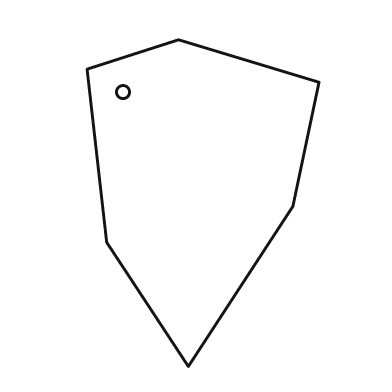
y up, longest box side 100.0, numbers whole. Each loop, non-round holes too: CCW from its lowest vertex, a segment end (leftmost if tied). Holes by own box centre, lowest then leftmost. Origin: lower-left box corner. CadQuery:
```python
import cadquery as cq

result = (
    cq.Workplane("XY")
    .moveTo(31.0, 0.0)
    .lineTo(63.0, 49.0)
    .lineTo(71.0, 87.0)
    .lineTo(28.0, 100.0)
    .lineTo(0.0, 91.0)
    .lineTo(6.0, 38.0)
    .close()
    .moveTo(11.0, 84.0)
    .circle(2.0)
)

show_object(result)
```